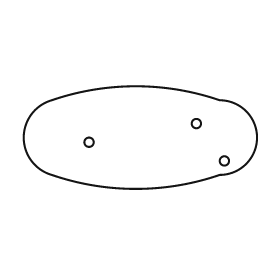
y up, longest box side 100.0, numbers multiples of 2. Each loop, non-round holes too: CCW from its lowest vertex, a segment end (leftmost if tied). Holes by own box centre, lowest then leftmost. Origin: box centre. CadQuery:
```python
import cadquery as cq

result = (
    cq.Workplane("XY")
    .moveTo(-38.0, -16.0)
    .threePointArc((-2.0, -22.0), (34.0, -16.0))
    .threePointArc((50.0, 0.0), (34.0, 16.0))
    .threePointArc((-2.0, 22.0), (-38.0, 16.0))
    .threePointArc((-50.0, 0.0), (-38.0, -16.0))
    .close()
    .moveTo(36.0, -10.0)
    .circle(2.0)
    .moveTo(-22.0, -2.0)
    .circle(2.0)
    .moveTo(24.0, 6.0)
    .circle(2.0)
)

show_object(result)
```